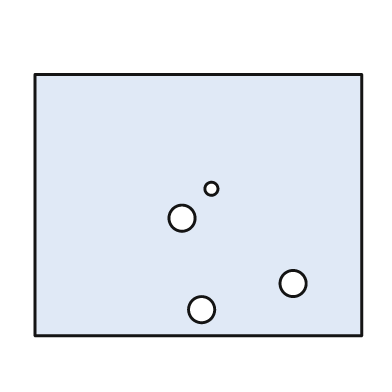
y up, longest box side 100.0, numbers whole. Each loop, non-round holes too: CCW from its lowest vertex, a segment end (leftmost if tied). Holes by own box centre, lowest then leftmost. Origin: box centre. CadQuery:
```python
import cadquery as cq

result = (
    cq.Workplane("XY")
    .moveTo(-50.0, -40.0)
    .lineTo(50.0, -40.0)
    .lineTo(50.0, 40.0)
    .lineTo(-50.0, 40.0)
    .close()
    .moveTo(1.0, -32.0)
    .circle(4.0)
    .moveTo(29.0, -24.0)
    .circle(4.0)
    .moveTo(-5.0, -4.0)
    .circle(4.0)
    .moveTo(4.0, 5.0)
    .circle(2.0)
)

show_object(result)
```